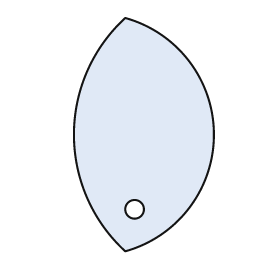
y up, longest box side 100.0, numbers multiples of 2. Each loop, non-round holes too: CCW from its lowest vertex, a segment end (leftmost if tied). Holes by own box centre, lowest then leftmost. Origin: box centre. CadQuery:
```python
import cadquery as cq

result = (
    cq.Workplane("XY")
    .moveTo(-8.0, -50.0)
    .threePointArc((30.0, 0.0), (-8.0, 50.0))
    .threePointArc((-30.0, 0.0), (-8.0, -50.0))
    .close()
    .moveTo(-4.0, -32.0)
    .circle(4.0)
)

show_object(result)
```